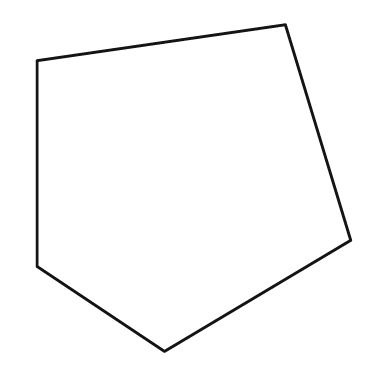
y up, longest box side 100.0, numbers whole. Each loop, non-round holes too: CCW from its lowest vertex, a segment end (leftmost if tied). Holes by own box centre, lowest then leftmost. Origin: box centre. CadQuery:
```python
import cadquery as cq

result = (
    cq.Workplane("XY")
    .moveTo(-9.0, -50.0)
    .lineTo(48.0, -16.0)
    .lineTo(28.0, 50.0)
    .lineTo(-48.0, 39.0)
    .lineTo(-48.0, -24.0)
    .close()
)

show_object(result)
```